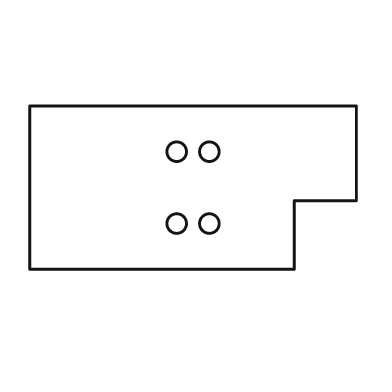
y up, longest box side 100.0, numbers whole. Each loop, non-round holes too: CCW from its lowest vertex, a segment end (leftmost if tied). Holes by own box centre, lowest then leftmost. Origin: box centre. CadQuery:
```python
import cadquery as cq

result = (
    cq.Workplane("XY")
    .moveTo(-50.0, -25.0)
    .lineTo(31.0, -25.0)
    .lineTo(31.0, -4.0)
    .lineTo(50.0, -4.0)
    .lineTo(50.0, 25.0)
    .lineTo(-50.0, 25.0)
    .close()
    .moveTo(-5.0, -11.0)
    .circle(3.0)
    .moveTo(5.0, -11.0)
    .circle(3.0)
    .moveTo(-5.0, 11.0)
    .circle(3.0)
    .moveTo(5.0, 11.0)
    .circle(3.0)
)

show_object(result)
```